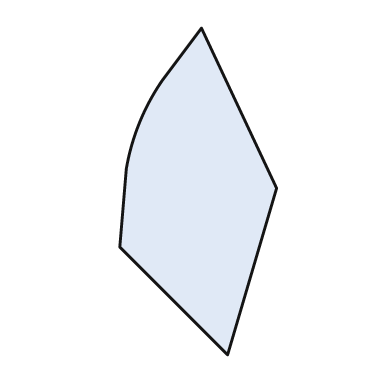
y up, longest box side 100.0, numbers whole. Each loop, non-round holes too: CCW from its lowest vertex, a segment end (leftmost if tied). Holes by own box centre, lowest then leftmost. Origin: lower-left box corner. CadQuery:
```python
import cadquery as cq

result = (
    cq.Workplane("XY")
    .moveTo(33.0, 0.0)
    .lineTo(48.0, 51.0)
    .lineTo(25.0, 100.0)
    .lineTo(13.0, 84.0)
    .threePointArc((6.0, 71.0), (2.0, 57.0))
    .lineTo(0.0, 33.0)
    .close()
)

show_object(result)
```